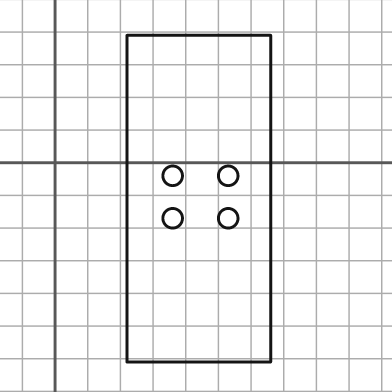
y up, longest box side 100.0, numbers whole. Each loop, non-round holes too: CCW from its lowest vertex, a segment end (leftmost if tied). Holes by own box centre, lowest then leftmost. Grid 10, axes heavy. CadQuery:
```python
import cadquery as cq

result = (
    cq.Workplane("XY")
    .moveTo(22.0, -61.0)
    .lineTo(66.0, -61.0)
    .lineTo(66.0, 39.0)
    .lineTo(22.0, 39.0)
    .close()
    .moveTo(36.0, -17.0)
    .circle(3.0)
    .moveTo(53.0, -17.0)
    .circle(3.0)
    .moveTo(36.0, -4.0)
    .circle(3.0)
    .moveTo(53.0, -4.0)
    .circle(3.0)
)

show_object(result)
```